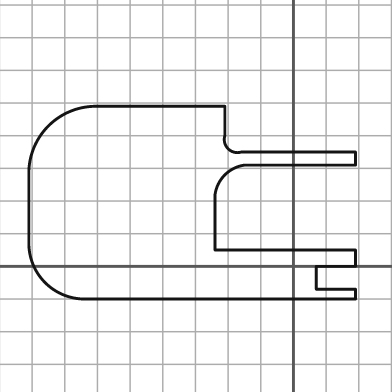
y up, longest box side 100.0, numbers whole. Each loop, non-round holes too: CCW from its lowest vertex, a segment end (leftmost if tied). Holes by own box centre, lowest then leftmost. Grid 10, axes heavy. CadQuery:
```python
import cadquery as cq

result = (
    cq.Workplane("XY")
    .moveTo(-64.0, -10.0)
    .lineTo(19.0, -10.0)
    .lineTo(19.0, -7.0)
    .lineTo(7.0, -7.0)
    .lineTo(7.0, 0.0)
    .lineTo(19.0, 0.0)
    .lineTo(19.0, 5.0)
    .lineTo(-24.0, 5.0)
    .lineTo(-24.0, 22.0)
    .threePointArc((-21.0, 28.0), (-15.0, 31.0))
    .lineTo(19.0, 31.0)
    .lineTo(19.0, 35.0)
    .lineTo(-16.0, 35.0)
    .threePointArc((-20.0, 36.0), (-21.0, 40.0))
    .lineTo(-21.0, 49.0)
    .lineTo(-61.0, 49.0)
    .threePointArc((-75.0, 43.0), (-81.0, 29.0))
    .lineTo(-81.0, 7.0)
    .threePointArc((-76.0, -5.0), (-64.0, -10.0))
    .close()
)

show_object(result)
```